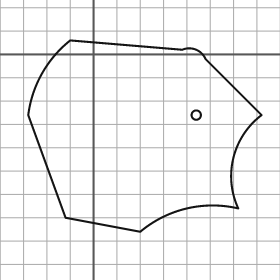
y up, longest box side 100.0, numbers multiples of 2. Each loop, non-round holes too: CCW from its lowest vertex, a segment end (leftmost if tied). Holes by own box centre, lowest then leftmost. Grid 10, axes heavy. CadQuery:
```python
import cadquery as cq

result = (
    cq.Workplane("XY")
    .moveTo(20.0, -76.0)
    .threePointArc((40.0, -66.0), (62.0, -66.0))
    .threePointArc((60.0, -44.0), (72.0, -26.0))
    .lineTo(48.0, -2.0)
    .threePointArc((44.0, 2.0), (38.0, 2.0))
    .lineTo(-10.0, 6.0)
    .threePointArc((-22.0, -8.0), (-28.0, -26.0))
    .lineTo(-12.0, -70.0)
    .close()
    .moveTo(44.0, -26.0)
    .circle(2.0)
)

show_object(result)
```